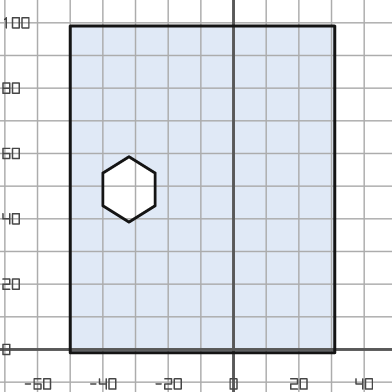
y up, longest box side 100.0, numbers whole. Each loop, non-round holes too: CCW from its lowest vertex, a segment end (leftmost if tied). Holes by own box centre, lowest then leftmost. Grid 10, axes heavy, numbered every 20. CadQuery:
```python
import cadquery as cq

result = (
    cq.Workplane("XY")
    .moveTo(-50.0, -1.0)
    .lineTo(31.0, -1.0)
    .lineTo(31.0, 99.0)
    .lineTo(-50.0, 99.0)
    .close()
    .moveTo(-32.0, 39.0)
    .lineTo(-24.0, 44.0)
    .lineTo(-24.0, 54.0)
    .lineTo(-32.0, 59.0)
    .lineTo(-40.0, 54.0)
    .lineTo(-40.0, 44.0)
    .close()
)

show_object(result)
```